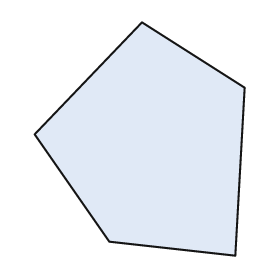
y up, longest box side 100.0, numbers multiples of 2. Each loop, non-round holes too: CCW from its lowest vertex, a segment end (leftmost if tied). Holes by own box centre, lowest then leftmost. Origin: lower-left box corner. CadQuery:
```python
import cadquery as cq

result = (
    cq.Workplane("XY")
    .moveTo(86.0, 0.0)
    .lineTo(90.0, 72.0)
    .lineTo(46.0, 100.0)
    .lineTo(0.0, 52.0)
    .lineTo(32.0, 6.0)
    .close()
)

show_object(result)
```